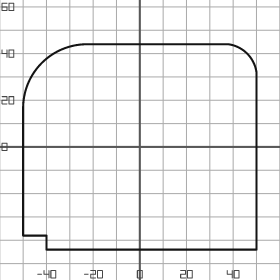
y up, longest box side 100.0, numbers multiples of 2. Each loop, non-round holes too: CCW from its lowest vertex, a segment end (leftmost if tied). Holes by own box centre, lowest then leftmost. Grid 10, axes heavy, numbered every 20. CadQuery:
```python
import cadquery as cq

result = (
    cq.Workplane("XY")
    .moveTo(-40.0, -44.0)
    .lineTo(50.0, -44.0)
    .lineTo(50.0, 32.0)
    .threePointArc((46.0, 40.0), (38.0, 44.0))
    .lineTo(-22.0, 44.0)
    .threePointArc((-42.0, 36.0), (-50.0, 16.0))
    .lineTo(-50.0, -38.0)
    .lineTo(-40.0, -38.0)
    .close()
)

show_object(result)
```